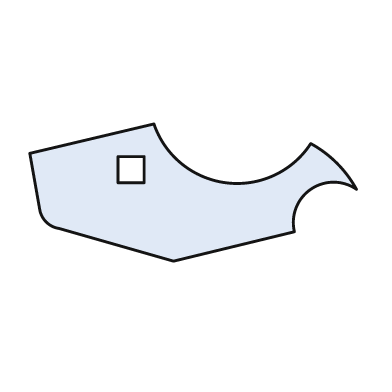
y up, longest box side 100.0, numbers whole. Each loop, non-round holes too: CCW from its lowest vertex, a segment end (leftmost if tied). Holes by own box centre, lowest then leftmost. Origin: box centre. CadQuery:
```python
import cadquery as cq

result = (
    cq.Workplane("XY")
    .moveTo(-6.0, -21.0)
    .lineTo(31.0, -12.0)
    .threePointArc((36.0, 1.0), (50.0, 1.0))
    .threePointArc((44.0, 9.0), (36.0, 15.0))
    .threePointArc((10.0, 3.0), (-12.0, 21.0))
    .lineTo(-50.0, 12.0)
    .lineTo(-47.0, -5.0)
    .threePointArc((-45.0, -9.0), (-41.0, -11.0))
    .close()
    .moveTo(-23.0, 3.0)
    .lineTo(-15.0, 3.0)
    .lineTo(-15.0, 11.0)
    .lineTo(-23.0, 11.0)
    .close()
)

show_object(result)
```